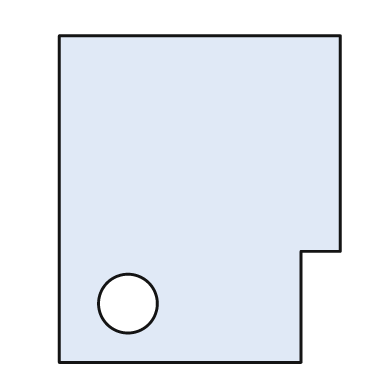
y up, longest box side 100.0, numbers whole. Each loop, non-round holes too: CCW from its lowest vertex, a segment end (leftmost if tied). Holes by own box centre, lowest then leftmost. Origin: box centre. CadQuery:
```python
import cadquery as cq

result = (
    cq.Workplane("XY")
    .moveTo(-43.0, -50.0)
    .lineTo(31.0, -50.0)
    .lineTo(31.0, -16.0)
    .lineTo(43.0, -16.0)
    .lineTo(43.0, 50.0)
    .lineTo(-43.0, 50.0)
    .close()
    .moveTo(-22.0, -32.0)
    .circle(9.0)
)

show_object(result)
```